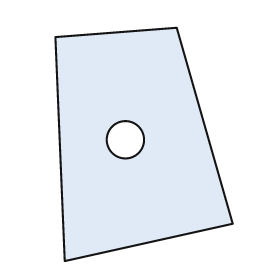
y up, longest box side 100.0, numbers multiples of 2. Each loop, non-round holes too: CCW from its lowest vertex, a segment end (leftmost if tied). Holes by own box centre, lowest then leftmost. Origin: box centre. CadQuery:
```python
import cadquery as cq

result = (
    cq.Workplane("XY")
    .moveTo(-34.0, -50.0)
    .lineTo(38.0, -34.0)
    .lineTo(14.0, 50.0)
    .lineTo(-38.0, 46.0)
    .close()
    .moveTo(-8.0, 2.0)
    .circle(8.0)
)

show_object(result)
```